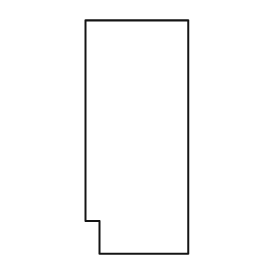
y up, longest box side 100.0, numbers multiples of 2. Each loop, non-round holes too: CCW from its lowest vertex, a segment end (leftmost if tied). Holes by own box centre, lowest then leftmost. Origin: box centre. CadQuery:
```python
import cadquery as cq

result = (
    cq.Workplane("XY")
    .moveTo(-16.0, -50.0)
    .lineTo(22.0, -50.0)
    .lineTo(22.0, 50.0)
    .lineTo(-22.0, 50.0)
    .lineTo(-22.0, -36.0)
    .lineTo(-16.0, -36.0)
    .close()
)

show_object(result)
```